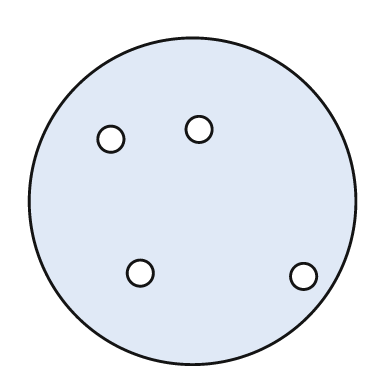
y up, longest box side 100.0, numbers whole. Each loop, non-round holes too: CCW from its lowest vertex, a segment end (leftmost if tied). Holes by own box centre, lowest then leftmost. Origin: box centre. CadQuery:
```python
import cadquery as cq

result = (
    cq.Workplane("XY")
    .moveTo(0.0, 0.0)
    .circle(50.0)
    .moveTo(34.0, -23.0)
    .circle(4.0)
    .moveTo(-16.0, -22.0)
    .circle(4.0)
    .moveTo(-25.0, 19.0)
    .circle(4.0)
    .moveTo(2.0, 22.0)
    .circle(4.0)
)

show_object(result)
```